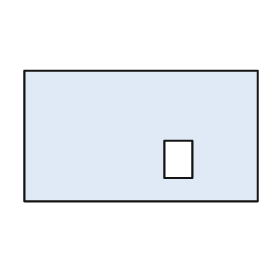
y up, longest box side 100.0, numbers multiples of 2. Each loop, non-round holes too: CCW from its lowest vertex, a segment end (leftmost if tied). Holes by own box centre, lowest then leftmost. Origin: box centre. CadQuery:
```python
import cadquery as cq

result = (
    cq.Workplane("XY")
    .moveTo(-50.0, -28.0)
    .lineTo(50.0, -28.0)
    .lineTo(50.0, 28.0)
    .lineTo(-50.0, 28.0)
    .close()
    .moveTo(10.0, -18.0)
    .lineTo(22.0, -18.0)
    .lineTo(22.0, -2.0)
    .lineTo(10.0, -2.0)
    .close()
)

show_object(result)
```